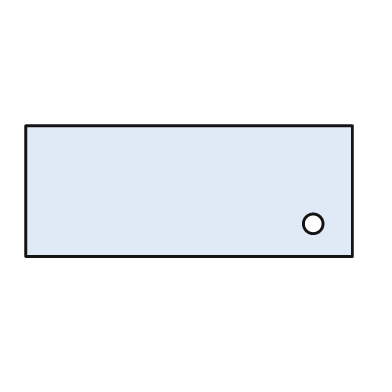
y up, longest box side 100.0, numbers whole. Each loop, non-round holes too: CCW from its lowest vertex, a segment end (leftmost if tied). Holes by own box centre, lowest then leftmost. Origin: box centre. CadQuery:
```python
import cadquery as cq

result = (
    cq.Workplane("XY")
    .moveTo(-50.0, -20.0)
    .lineTo(50.0, -20.0)
    .lineTo(50.0, 20.0)
    .lineTo(-50.0, 20.0)
    .close()
    .moveTo(38.0, -10.0)
    .circle(3.0)
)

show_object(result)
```